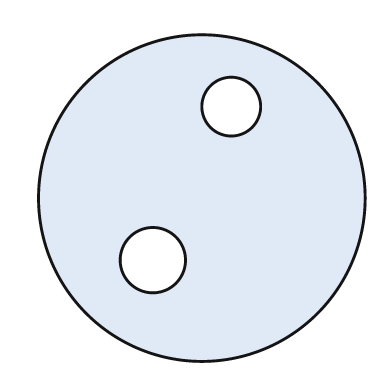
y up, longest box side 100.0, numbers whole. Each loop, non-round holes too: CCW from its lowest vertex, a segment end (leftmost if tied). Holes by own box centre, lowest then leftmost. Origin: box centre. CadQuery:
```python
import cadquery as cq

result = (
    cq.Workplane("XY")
    .moveTo(0.0, 0.0)
    .circle(50.0)
    .moveTo(-15.0, -19.0)
    .circle(10.0)
    .moveTo(9.0, 28.0)
    .circle(9.0)
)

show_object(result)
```